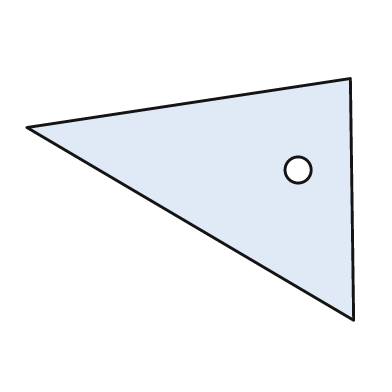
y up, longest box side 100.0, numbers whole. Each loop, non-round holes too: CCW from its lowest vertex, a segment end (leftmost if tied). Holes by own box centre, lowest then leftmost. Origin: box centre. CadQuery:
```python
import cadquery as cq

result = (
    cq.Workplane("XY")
    .moveTo(50.0, -37.0)
    .lineTo(49.0, 37.0)
    .lineTo(-50.0, 22.0)
    .close()
    .moveTo(33.0, 9.0)
    .circle(4.0)
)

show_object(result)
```